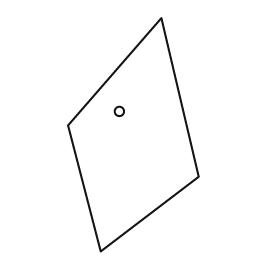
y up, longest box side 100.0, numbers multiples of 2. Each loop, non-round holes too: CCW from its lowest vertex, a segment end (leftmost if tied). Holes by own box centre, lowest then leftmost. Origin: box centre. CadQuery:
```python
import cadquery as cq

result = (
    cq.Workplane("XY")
    .moveTo(-14.0, -50.0)
    .lineTo(28.0, -18.0)
    .lineTo(12.0, 50.0)
    .lineTo(-28.0, 4.0)
    .close()
    .moveTo(-6.0, 10.0)
    .circle(2.0)
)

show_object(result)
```